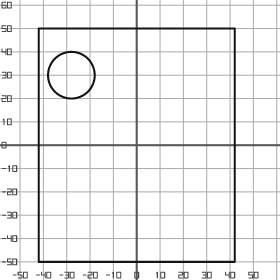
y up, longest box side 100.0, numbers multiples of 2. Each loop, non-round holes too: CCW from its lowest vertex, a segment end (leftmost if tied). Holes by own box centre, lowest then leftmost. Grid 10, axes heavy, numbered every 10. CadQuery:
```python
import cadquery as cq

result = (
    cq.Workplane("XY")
    .moveTo(-42.0, -50.0)
    .lineTo(42.0, -50.0)
    .lineTo(42.0, 50.0)
    .lineTo(-42.0, 50.0)
    .close()
    .moveTo(-28.0, 30.0)
    .circle(10.0)
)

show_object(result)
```